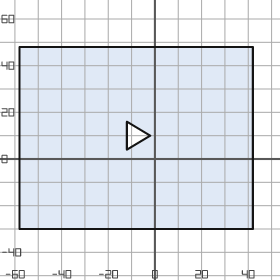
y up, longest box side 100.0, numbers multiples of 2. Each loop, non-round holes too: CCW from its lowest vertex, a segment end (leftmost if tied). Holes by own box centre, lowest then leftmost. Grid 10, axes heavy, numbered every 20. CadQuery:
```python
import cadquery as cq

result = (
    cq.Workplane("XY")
    .moveTo(-58.0, -30.0)
    .lineTo(42.0, -30.0)
    .lineTo(42.0, 48.0)
    .lineTo(-58.0, 48.0)
    .close()
    .moveTo(-12.0, 4.0)
    .lineTo(-2.0, 10.0)
    .lineTo(-12.0, 16.0)
    .close()
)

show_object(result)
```